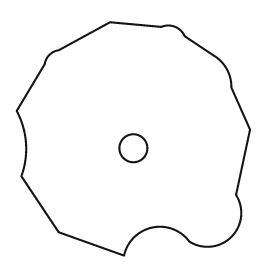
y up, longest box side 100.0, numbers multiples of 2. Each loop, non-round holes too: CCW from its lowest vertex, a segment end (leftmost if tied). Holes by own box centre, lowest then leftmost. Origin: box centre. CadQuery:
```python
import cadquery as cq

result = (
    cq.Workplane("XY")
    .moveTo(-4.0, -50.0)
    .threePointArc((8.0, -38.0), (24.0, -44.0))
    .threePointArc((42.0, -42.0), (44.0, -24.0))
    .lineTo(50.0, 4.0)
    .lineTo(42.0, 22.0)
    .threePointArc((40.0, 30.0), (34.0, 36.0))
    .lineTo(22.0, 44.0)
    .threePointArc((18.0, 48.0), (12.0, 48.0))
    .lineTo(-10.0, 50.0)
    .lineTo(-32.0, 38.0)
    .threePointArc((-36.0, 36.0), (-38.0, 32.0))
    .lineTo(-50.0, 12.0)
    .threePointArc((-46.0, -2.0), (-48.0, -16.0))
    .lineTo(-32.0, -40.0)
    .close()
    .moveTo(0.0, -4.0)
    .circle(6.0)
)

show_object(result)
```